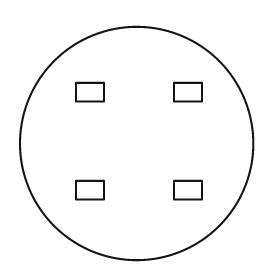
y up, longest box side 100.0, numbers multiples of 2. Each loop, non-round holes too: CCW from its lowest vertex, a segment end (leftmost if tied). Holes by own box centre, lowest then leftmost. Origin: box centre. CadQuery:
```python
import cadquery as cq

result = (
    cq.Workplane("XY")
    .moveTo(0.0, 0.0)
    .circle(50.0)
    .moveTo(-26.0, -24.0)
    .lineTo(-14.0, -24.0)
    .lineTo(-14.0, -16.0)
    .lineTo(-26.0, -16.0)
    .close()
    .moveTo(16.0, -24.0)
    .lineTo(28.0, -24.0)
    .lineTo(28.0, -16.0)
    .lineTo(16.0, -16.0)
    .close()
    .moveTo(-26.0, 18.0)
    .lineTo(-14.0, 18.0)
    .lineTo(-14.0, 26.0)
    .lineTo(-26.0, 26.0)
    .close()
    .moveTo(16.0, 18.0)
    .lineTo(28.0, 18.0)
    .lineTo(28.0, 26.0)
    .lineTo(16.0, 26.0)
    .close()
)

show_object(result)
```